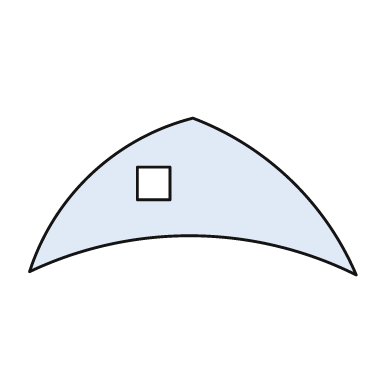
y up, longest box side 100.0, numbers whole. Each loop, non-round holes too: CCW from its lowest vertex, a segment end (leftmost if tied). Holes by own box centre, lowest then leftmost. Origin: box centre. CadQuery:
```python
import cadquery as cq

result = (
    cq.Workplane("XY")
    .moveTo(50.0, -24.0)
    .threePointArc((30.0, 5.0), (0.0, 24.0))
    .threePointArc((-31.0, 7.0), (-50.0, -23.0))
    .threePointArc((0.0, -12.0), (50.0, -24.0))
    .close()
    .moveTo(-17.0, -1.0)
    .lineTo(-7.0, -1.0)
    .lineTo(-7.0, 9.0)
    .lineTo(-17.0, 9.0)
    .close()
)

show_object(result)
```